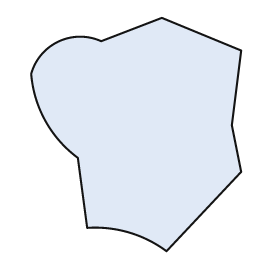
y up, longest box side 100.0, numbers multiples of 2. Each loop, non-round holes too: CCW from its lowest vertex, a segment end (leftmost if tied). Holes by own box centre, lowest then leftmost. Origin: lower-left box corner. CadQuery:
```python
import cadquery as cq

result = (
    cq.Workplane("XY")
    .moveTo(58.0, 0.0)
    .lineTo(90.0, 34.0)
    .lineTo(86.0, 54.0)
    .lineTo(90.0, 86.0)
    .lineTo(56.0, 100.0)
    .lineTo(30.0, 90.0)
    .threePointArc((12.0, 90.0), (0.0, 76.0))
    .threePointArc((6.0, 56.0), (20.0, 40.0))
    .lineTo(24.0, 10.0)
    .threePointArc((42.0, 8.0), (58.0, 0.0))
    .close()
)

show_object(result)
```